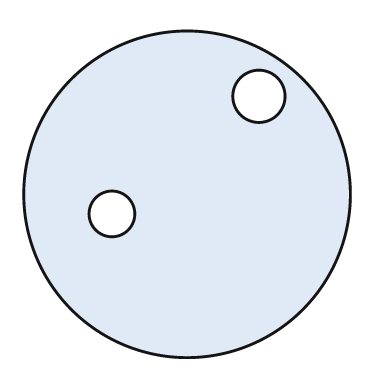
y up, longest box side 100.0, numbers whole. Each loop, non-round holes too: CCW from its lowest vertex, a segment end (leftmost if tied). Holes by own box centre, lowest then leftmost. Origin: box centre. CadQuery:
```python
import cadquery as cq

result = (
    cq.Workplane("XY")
    .moveTo(0.0, 0.0)
    .circle(50.0)
    .moveTo(-23.0, -6.0)
    .circle(7.0)
    .moveTo(22.0, 30.0)
    .circle(8.0)
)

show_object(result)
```